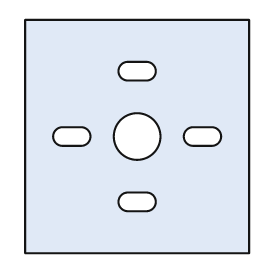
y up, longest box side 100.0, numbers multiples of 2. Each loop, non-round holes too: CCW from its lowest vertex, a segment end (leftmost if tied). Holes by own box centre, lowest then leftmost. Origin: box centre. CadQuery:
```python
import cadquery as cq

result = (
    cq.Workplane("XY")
    .moveTo(-48.0, -50.0)
    .lineTo(48.0, -50.0)
    .lineTo(48.0, 50.0)
    .lineTo(-48.0, 50.0)
    .close()
    .moveTo(-4.0, -32.0)
    .lineTo(4.0, -32.0)
    .threePointArc((8.0, -28.0), (4.0, -24.0))
    .lineTo(-4.0, -24.0)
    .threePointArc((-8.0, -28.0), (-4.0, -32.0))
    .close()
    .moveTo(-32.0, -4.0)
    .lineTo(-24.0, -4.0)
    .threePointArc((-20.0, 0.0), (-24.0, 4.0))
    .lineTo(-32.0, 4.0)
    .threePointArc((-36.0, 0.0), (-32.0, -4.0))
    .close()
    .moveTo(0.0, 0.0)
    .circle(10.0)
    .moveTo(24.0, -4.0)
    .lineTo(32.0, -4.0)
    .threePointArc((36.0, 0.0), (32.0, 4.0))
    .lineTo(24.0, 4.0)
    .threePointArc((20.0, 0.0), (24.0, -4.0))
    .close()
    .moveTo(-4.0, 24.0)
    .lineTo(4.0, 24.0)
    .threePointArc((8.0, 28.0), (4.0, 32.0))
    .lineTo(-4.0, 32.0)
    .threePointArc((-8.0, 28.0), (-4.0, 24.0))
    .close()
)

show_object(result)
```